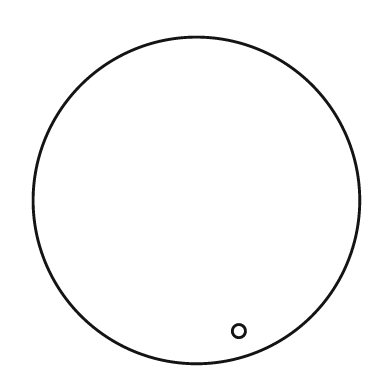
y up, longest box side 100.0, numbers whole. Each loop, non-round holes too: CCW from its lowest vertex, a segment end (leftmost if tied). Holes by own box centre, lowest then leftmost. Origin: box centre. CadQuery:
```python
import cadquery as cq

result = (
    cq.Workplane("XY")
    .moveTo(0.0, 0.0)
    .circle(50.0)
    .moveTo(13.0, -40.0)
    .circle(2.0)
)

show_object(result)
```